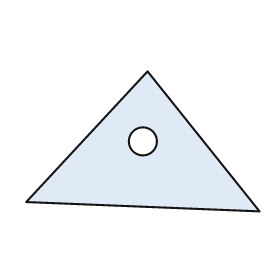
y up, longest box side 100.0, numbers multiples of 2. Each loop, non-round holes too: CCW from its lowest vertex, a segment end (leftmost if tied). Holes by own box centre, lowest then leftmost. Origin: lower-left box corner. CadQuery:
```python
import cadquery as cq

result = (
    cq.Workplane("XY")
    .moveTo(100.0, 0.0)
    .lineTo(52.0, 60.0)
    .lineTo(0.0, 4.0)
    .close()
    .moveTo(50.0, 30.0)
    .circle(6.0)
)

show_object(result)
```